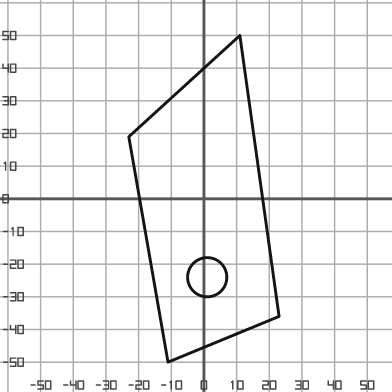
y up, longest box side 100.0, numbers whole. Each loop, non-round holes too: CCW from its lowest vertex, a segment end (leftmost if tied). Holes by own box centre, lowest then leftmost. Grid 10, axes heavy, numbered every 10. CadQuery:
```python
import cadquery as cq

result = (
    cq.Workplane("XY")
    .moveTo(-11.0, -50.0)
    .lineTo(23.0, -36.0)
    .lineTo(11.0, 50.0)
    .lineTo(-23.0, 19.0)
    .close()
    .moveTo(1.0, -24.0)
    .circle(6.0)
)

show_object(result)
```